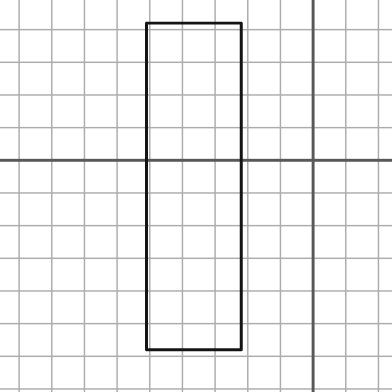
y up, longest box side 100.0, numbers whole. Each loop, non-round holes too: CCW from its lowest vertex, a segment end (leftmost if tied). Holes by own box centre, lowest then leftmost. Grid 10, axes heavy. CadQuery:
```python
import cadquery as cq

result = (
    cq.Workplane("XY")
    .moveTo(-51.0, -58.0)
    .lineTo(-22.0, -58.0)
    .lineTo(-22.0, 42.0)
    .lineTo(-51.0, 42.0)
    .close()
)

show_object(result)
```